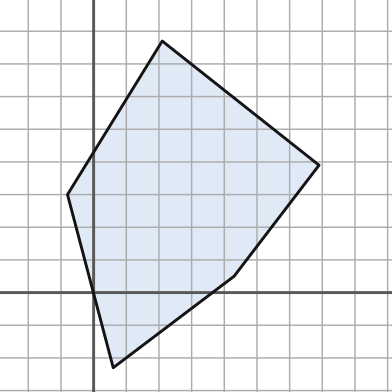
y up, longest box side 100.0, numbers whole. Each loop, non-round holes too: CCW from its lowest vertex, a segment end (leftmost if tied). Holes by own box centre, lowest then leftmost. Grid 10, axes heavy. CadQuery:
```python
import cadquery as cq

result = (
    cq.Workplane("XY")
    .moveTo(6.0, -23.0)
    .lineTo(43.0, 5.0)
    .lineTo(69.0, 39.0)
    .lineTo(21.0, 77.0)
    .lineTo(-8.0, 30.0)
    .close()
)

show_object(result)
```